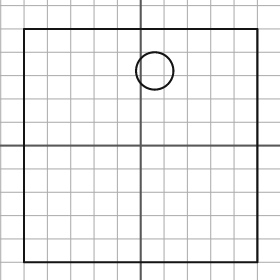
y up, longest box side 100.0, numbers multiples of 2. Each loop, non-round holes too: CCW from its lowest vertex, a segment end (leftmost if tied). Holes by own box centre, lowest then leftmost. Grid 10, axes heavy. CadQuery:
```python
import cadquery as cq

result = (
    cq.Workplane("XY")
    .moveTo(-50.0, -50.0)
    .lineTo(50.0, -50.0)
    .lineTo(50.0, 50.0)
    .lineTo(-50.0, 50.0)
    .close()
    .moveTo(6.0, 32.0)
    .circle(8.0)
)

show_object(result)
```